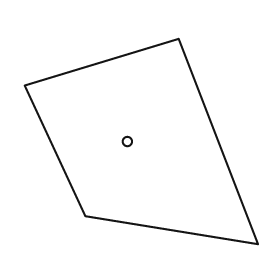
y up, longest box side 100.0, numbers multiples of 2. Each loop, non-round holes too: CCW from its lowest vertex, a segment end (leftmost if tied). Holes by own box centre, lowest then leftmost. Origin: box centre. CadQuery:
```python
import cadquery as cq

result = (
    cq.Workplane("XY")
    .moveTo(50.0, -44.0)
    .lineTo(16.0, 44.0)
    .lineTo(-50.0, 24.0)
    .lineTo(-24.0, -32.0)
    .close()
    .moveTo(-6.0, 0.0)
    .circle(2.0)
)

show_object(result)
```